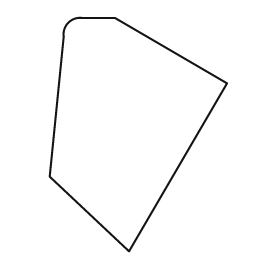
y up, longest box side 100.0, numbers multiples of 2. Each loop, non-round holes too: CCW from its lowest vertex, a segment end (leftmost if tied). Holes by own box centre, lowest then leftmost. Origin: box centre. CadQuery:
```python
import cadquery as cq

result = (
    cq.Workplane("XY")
    .moveTo(-4.0, -50.0)
    .lineTo(38.0, 22.0)
    .lineTo(-10.0, 50.0)
    .lineTo(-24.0, 50.0)
    .threePointArc((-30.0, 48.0), (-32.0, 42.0))
    .lineTo(-38.0, -18.0)
    .close()
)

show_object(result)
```